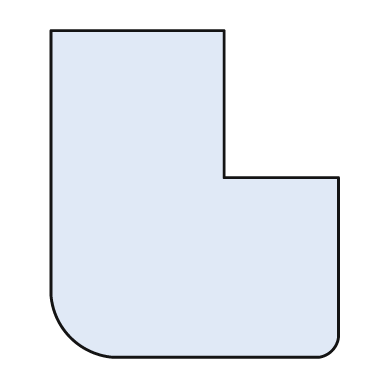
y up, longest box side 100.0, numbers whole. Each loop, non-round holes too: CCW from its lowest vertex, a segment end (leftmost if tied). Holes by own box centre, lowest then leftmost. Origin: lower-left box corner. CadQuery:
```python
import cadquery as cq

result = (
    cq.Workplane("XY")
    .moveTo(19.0, 0.0)
    .lineTo(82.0, 0.0)
    .threePointArc((86.0, 2.0), (88.0, 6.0))
    .lineTo(88.0, 55.0)
    .lineTo(53.0, 55.0)
    .lineTo(53.0, 100.0)
    .lineTo(0.0, 100.0)
    .lineTo(0.0, 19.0)
    .threePointArc((6.0, 6.0), (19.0, 0.0))
    .close()
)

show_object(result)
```